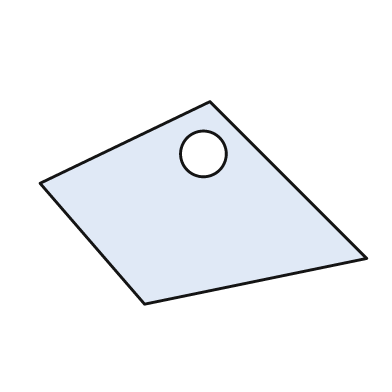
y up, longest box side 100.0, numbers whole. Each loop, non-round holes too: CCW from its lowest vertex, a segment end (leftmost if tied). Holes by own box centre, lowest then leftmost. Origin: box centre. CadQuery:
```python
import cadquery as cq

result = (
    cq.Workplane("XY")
    .moveTo(-18.0, -31.0)
    .lineTo(50.0, -17.0)
    .lineTo(2.0, 31.0)
    .lineTo(-50.0, 6.0)
    .close()
    .moveTo(0.0, 15.0)
    .circle(7.0)
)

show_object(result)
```